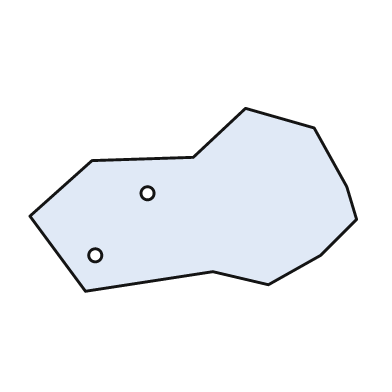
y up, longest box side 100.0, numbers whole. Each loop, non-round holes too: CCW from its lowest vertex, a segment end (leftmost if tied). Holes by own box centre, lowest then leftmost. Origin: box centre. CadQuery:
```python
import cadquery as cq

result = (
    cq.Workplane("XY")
    .moveTo(-33.0, -28.0)
    .lineTo(6.0, -22.0)
    .lineTo(23.0, -26.0)
    .lineTo(39.0, -17.0)
    .lineTo(50.0, -6.0)
    .lineTo(47.0, 4.0)
    .lineTo(37.0, 22.0)
    .lineTo(16.0, 28.0)
    .lineTo(0.0, 13.0)
    .lineTo(-31.0, 12.0)
    .lineTo(-50.0, -5.0)
    .close()
    .moveTo(-30.0, -17.0)
    .circle(2.0)
    .moveTo(-14.0, 2.0)
    .circle(2.0)
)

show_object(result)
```